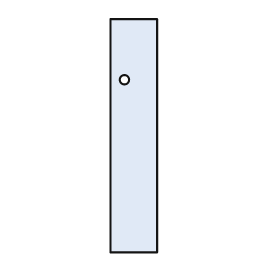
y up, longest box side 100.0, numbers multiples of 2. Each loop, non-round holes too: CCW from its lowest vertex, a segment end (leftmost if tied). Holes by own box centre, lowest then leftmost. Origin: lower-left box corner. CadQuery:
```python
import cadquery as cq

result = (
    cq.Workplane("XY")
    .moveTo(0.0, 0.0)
    .lineTo(20.0, 0.0)
    .lineTo(20.0, 100.0)
    .lineTo(0.0, 100.0)
    .close()
    .moveTo(6.0, 74.0)
    .circle(2.0)
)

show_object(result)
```